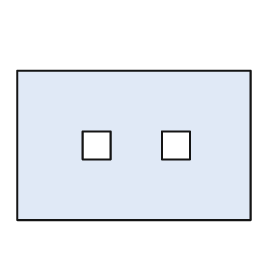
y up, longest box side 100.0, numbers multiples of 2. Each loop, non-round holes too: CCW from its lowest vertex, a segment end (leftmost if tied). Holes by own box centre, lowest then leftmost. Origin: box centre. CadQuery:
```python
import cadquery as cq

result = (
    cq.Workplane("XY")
    .moveTo(-50.0, -32.0)
    .lineTo(50.0, -32.0)
    .lineTo(50.0, 32.0)
    .lineTo(-50.0, 32.0)
    .close()
    .moveTo(-22.0, -6.0)
    .lineTo(-10.0, -6.0)
    .lineTo(-10.0, 6.0)
    .lineTo(-22.0, 6.0)
    .close()
    .moveTo(12.0, -6.0)
    .lineTo(24.0, -6.0)
    .lineTo(24.0, 6.0)
    .lineTo(12.0, 6.0)
    .close()
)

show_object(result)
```